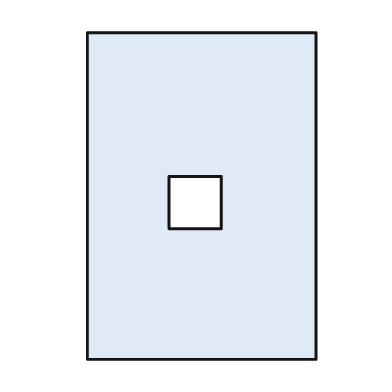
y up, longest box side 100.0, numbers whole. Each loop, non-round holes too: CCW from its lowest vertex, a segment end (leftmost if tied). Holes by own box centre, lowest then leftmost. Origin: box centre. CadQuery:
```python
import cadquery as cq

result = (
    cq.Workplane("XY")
    .moveTo(-35.0, -50.0)
    .lineTo(35.0, -50.0)
    .lineTo(35.0, 50.0)
    .lineTo(-35.0, 50.0)
    .close()
    .moveTo(-10.0, -10.0)
    .lineTo(6.0, -10.0)
    .lineTo(6.0, 6.0)
    .lineTo(-10.0, 6.0)
    .close()
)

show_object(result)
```